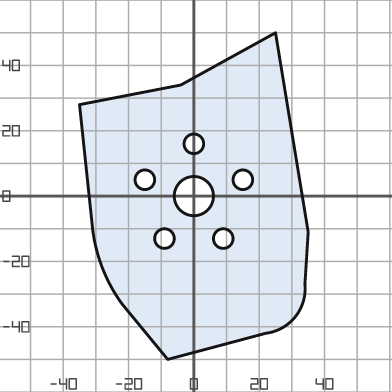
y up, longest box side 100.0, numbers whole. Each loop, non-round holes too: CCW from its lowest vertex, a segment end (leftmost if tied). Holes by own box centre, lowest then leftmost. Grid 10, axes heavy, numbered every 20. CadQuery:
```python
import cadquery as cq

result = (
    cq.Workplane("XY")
    .moveTo(-8.0, -50.0)
    .lineTo(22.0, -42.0)
    .threePointArc((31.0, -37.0), (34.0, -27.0))
    .lineTo(35.0, -11.0)
    .lineTo(25.0, 50.0)
    .lineTo(-4.0, 34.0)
    .lineTo(-35.0, 28.0)
    .lineTo(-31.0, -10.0)
    .threePointArc((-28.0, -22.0), (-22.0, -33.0))
    .close()
    .moveTo(-9.0, -13.0)
    .circle(3.0)
    .moveTo(9.0, -13.0)
    .circle(3.0)
    .moveTo(0.0, 0.0)
    .circle(6.0)
    .moveTo(-15.0, 5.0)
    .circle(3.0)
    .moveTo(15.0, 5.0)
    .circle(3.0)
    .moveTo(0.0, 16.0)
    .circle(3.0)
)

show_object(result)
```